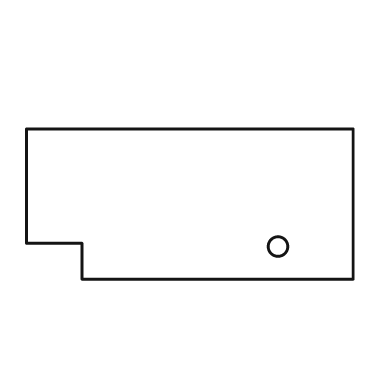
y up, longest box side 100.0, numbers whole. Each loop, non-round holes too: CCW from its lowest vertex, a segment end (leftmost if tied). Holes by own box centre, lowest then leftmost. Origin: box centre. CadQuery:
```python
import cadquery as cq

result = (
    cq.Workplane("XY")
    .moveTo(-33.0, -23.0)
    .lineTo(50.0, -23.0)
    .lineTo(50.0, 23.0)
    .lineTo(-50.0, 23.0)
    .lineTo(-50.0, -12.0)
    .lineTo(-33.0, -12.0)
    .close()
    .moveTo(27.0, -13.0)
    .circle(3.0)
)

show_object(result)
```